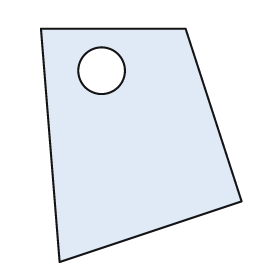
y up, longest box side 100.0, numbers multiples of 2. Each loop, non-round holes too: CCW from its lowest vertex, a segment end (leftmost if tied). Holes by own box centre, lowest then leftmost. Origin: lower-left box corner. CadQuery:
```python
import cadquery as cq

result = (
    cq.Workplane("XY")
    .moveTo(8.0, 0.0)
    .lineTo(86.0, 26.0)
    .lineTo(62.0, 100.0)
    .lineTo(0.0, 100.0)
    .close()
    .moveTo(26.0, 82.0)
    .circle(10.0)
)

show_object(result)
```